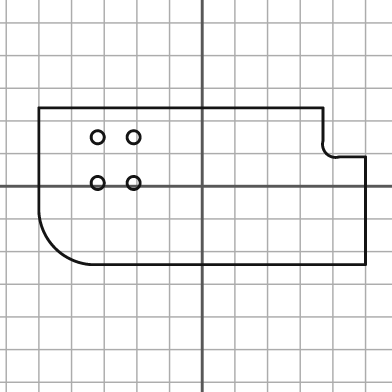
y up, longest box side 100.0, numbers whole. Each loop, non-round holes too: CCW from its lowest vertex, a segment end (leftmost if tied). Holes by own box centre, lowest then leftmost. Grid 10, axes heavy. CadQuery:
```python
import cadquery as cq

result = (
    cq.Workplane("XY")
    .moveTo(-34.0, -24.0)
    .lineTo(50.0, -24.0)
    .lineTo(50.0, 9.0)
    .lineTo(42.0, 9.0)
    .threePointArc((38.0, 10.0), (37.0, 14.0))
    .lineTo(37.0, 24.0)
    .lineTo(-50.0, 24.0)
    .lineTo(-50.0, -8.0)
    .threePointArc((-45.0, -19.0), (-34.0, -24.0))
    .close()
    .moveTo(-32.0, 1.0)
    .circle(2.0)
    .moveTo(-21.0, 1.0)
    .circle(2.0)
    .moveTo(-32.0, 15.0)
    .circle(2.0)
    .moveTo(-21.0, 15.0)
    .circle(2.0)
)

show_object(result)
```